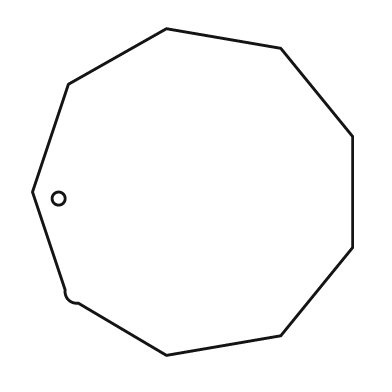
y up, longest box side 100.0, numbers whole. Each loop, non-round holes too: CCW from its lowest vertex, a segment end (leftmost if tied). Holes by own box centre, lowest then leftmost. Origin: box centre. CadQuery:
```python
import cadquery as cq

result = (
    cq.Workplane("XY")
    .moveTo(-8.0, -50.0)
    .lineTo(27.0, -44.0)
    .lineTo(49.0, -17.0)
    .lineTo(49.0, 17.0)
    .lineTo(27.0, 44.0)
    .lineTo(-8.0, 50.0)
    .lineTo(-38.0, 33.0)
    .lineTo(-49.0, 0.0)
    .lineTo(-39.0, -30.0)
    .threePointArc((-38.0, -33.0), (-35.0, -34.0))
    .close()
    .moveTo(-41.0, -2.0)
    .circle(2.0)
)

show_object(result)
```